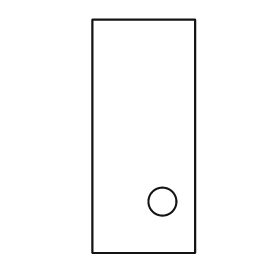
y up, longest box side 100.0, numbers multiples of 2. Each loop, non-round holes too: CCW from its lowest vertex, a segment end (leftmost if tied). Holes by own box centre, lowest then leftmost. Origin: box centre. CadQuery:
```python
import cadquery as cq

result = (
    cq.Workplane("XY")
    .moveTo(-22.0, -50.0)
    .lineTo(22.0, -50.0)
    .lineTo(22.0, 50.0)
    .lineTo(-22.0, 50.0)
    .close()
    .moveTo(8.0, -28.0)
    .circle(6.0)
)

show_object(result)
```